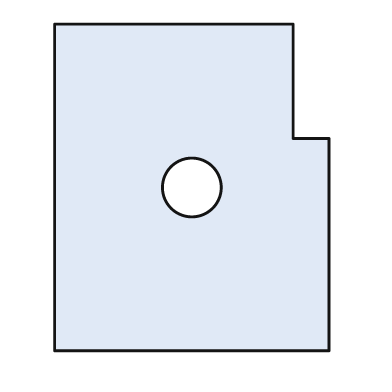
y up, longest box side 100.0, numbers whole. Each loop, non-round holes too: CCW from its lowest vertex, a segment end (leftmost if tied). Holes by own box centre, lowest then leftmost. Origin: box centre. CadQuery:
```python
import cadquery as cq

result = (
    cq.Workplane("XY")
    .moveTo(-42.0, -50.0)
    .lineTo(42.0, -50.0)
    .lineTo(42.0, 15.0)
    .lineTo(31.0, 15.0)
    .lineTo(31.0, 50.0)
    .lineTo(-42.0, 50.0)
    .close()
    .moveTo(0.0, 0.0)
    .circle(9.0)
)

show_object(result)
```